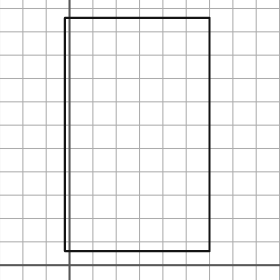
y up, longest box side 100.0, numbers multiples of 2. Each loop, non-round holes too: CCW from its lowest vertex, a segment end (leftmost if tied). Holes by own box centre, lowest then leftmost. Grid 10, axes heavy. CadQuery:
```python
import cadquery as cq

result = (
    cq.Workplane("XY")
    .moveTo(-2.0, 6.0)
    .lineTo(60.0, 6.0)
    .lineTo(60.0, 106.0)
    .lineTo(-2.0, 106.0)
    .close()
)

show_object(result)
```